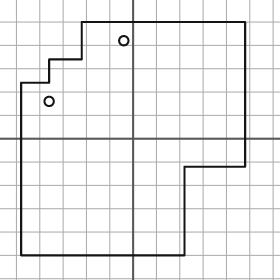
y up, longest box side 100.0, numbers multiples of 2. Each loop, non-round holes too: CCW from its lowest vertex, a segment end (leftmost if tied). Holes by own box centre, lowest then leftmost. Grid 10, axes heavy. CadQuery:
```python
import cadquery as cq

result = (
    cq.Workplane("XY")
    .moveTo(-48.0, -50.0)
    .lineTo(22.0, -50.0)
    .lineTo(22.0, -12.0)
    .lineTo(48.0, -12.0)
    .lineTo(48.0, 50.0)
    .lineTo(-22.0, 50.0)
    .lineTo(-22.0, 34.0)
    .lineTo(-36.0, 34.0)
    .lineTo(-36.0, 24.0)
    .lineTo(-48.0, 24.0)
    .close()
    .moveTo(-36.0, 16.0)
    .circle(2.0)
    .moveTo(-4.0, 42.0)
    .circle(2.0)
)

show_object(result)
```